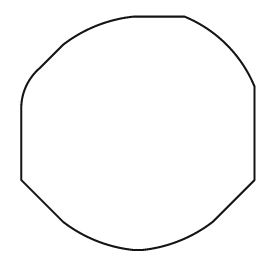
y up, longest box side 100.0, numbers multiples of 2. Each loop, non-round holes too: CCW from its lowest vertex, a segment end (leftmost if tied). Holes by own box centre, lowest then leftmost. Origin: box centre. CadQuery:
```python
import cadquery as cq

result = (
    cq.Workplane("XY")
    .moveTo(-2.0, -50.0)
    .lineTo(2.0, -50.0)
    .threePointArc((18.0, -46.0), (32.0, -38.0))
    .lineTo(50.0, -20.0)
    .lineTo(50.0, 20.0)
    .threePointArc((38.0, 38.0), (20.0, 50.0))
    .lineTo(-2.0, 50.0)
    .threePointArc((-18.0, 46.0), (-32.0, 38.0))
    .lineTo(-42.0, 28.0)
    .threePointArc((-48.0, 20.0), (-50.0, 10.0))
    .lineTo(-50.0, -20.0)
    .lineTo(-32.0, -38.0)
    .threePointArc((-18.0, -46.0), (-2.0, -50.0))
    .close()
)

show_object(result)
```